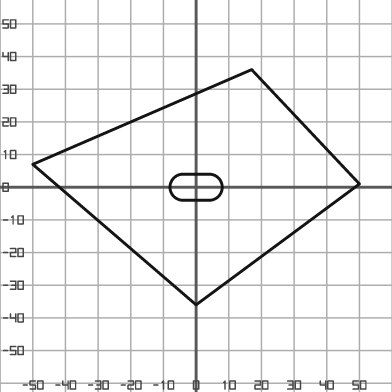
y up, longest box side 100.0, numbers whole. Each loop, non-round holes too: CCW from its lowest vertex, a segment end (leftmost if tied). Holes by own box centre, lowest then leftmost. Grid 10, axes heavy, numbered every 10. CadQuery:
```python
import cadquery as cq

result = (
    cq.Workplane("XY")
    .moveTo(0.0, -36.0)
    .lineTo(50.0, 1.0)
    .lineTo(17.0, 36.0)
    .lineTo(-50.0, 7.0)
    .close()
    .moveTo(-4.0, -4.0)
    .lineTo(4.0, -4.0)
    .threePointArc((8.0, 0.0), (4.0, 4.0))
    .lineTo(-4.0, 4.0)
    .threePointArc((-8.0, 0.0), (-4.0, -4.0))
    .close()
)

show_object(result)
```